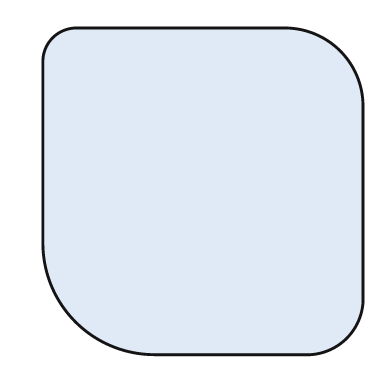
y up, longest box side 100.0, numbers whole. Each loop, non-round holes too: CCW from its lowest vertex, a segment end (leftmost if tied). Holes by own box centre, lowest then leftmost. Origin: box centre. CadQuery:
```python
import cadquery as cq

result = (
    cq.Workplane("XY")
    .moveTo(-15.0, -50.0)
    .lineTo(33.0, -50.0)
    .threePointArc((44.0, -45.0), (49.0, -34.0))
    .lineTo(49.0, 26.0)
    .threePointArc((42.0, 43.0), (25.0, 50.0))
    .lineTo(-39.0, 50.0)
    .threePointArc((-46.0, 47.0), (-49.0, 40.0))
    .lineTo(-49.0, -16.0)
    .threePointArc((-39.0, -40.0), (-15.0, -50.0))
    .close()
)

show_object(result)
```